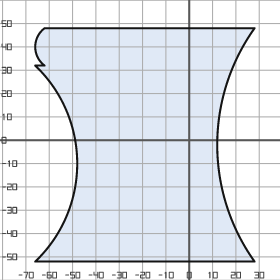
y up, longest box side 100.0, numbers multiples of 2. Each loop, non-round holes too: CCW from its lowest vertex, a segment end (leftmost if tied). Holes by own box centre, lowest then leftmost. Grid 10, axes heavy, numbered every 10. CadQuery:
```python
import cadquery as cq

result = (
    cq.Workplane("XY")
    .moveTo(-66.0, -52.0)
    .lineTo(28.0, -52.0)
    .threePointArc((12.0, -2.0), (28.0, 48.0))
    .lineTo(-62.0, 48.0)
    .threePointArc((-66.0, 40.0), (-62.0, 32.0))
    .lineTo(-66.0, 32.0)
    .threePointArc((-48.0, -10.0), (-66.0, -52.0))
    .close()
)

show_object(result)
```